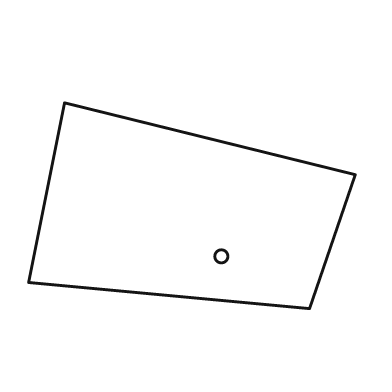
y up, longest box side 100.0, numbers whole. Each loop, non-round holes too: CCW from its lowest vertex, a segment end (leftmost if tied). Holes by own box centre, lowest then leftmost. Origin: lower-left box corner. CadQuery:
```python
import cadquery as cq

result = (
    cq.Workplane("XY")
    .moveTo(86.0, 0.0)
    .lineTo(100.0, 41.0)
    .lineTo(11.0, 63.0)
    .lineTo(0.0, 8.0)
    .close()
    .moveTo(59.0, 16.0)
    .circle(2.0)
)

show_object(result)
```